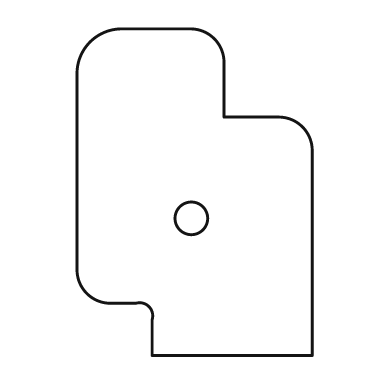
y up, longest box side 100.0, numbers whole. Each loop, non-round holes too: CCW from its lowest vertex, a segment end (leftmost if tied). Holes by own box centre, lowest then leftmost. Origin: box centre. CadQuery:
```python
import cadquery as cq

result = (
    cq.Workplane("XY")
    .moveTo(-13.0, -50.0)
    .lineTo(36.0, -50.0)
    .lineTo(36.0, 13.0)
    .threePointArc((33.0, 20.0), (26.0, 23.0))
    .lineTo(9.0, 23.0)
    .lineTo(9.0, 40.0)
    .threePointArc((6.0, 47.0), (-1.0, 50.0))
    .lineTo(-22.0, 50.0)
    .threePointArc((-32.0, 46.0), (-36.0, 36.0))
    .lineTo(-36.0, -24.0)
    .threePointArc((-33.0, -31.0), (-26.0, -34.0))
    .lineTo(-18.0, -34.0)
    .threePointArc((-14.0, -35.0), (-13.0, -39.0))
    .close()
    .moveTo(-1.0, -8.0)
    .circle(5.0)
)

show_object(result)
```